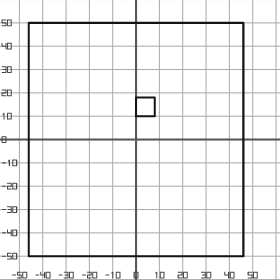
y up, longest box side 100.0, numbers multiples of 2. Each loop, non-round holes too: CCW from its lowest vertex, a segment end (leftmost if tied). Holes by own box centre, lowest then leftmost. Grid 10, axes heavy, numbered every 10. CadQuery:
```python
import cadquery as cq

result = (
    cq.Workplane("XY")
    .moveTo(-46.0, -50.0)
    .lineTo(46.0, -50.0)
    .lineTo(46.0, 50.0)
    .lineTo(-46.0, 50.0)
    .close()
    .moveTo(0.0, 10.0)
    .lineTo(8.0, 10.0)
    .lineTo(8.0, 18.0)
    .lineTo(0.0, 18.0)
    .close()
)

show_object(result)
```